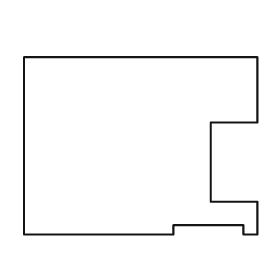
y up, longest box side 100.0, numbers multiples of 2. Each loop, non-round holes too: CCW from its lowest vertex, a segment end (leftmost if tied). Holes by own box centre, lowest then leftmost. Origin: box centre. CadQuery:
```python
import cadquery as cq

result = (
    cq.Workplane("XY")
    .moveTo(-50.0, -38.0)
    .lineTo(14.0, -38.0)
    .lineTo(14.0, -34.0)
    .lineTo(44.0, -34.0)
    .lineTo(44.0, -38.0)
    .lineTo(50.0, -38.0)
    .lineTo(50.0, -24.0)
    .lineTo(30.0, -24.0)
    .lineTo(30.0, 10.0)
    .lineTo(50.0, 10.0)
    .lineTo(50.0, 38.0)
    .lineTo(-50.0, 38.0)
    .close()
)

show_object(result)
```